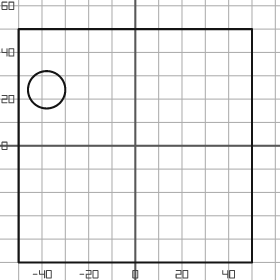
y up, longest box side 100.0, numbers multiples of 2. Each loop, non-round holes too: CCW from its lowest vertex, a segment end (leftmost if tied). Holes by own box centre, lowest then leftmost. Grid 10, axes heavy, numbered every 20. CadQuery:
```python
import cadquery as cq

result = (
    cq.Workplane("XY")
    .moveTo(-50.0, -50.0)
    .lineTo(50.0, -50.0)
    .lineTo(50.0, 50.0)
    .lineTo(-50.0, 50.0)
    .close()
    .moveTo(-38.0, 24.0)
    .circle(8.0)
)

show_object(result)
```